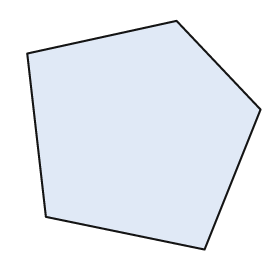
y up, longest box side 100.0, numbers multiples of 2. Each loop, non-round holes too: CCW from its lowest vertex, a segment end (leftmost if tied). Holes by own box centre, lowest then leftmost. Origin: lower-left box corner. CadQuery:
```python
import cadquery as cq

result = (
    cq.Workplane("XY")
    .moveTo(76.0, 0.0)
    .lineTo(100.0, 60.0)
    .lineTo(64.0, 98.0)
    .lineTo(0.0, 84.0)
    .lineTo(8.0, 14.0)
    .close()
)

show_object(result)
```